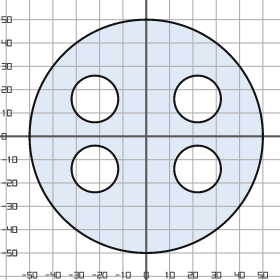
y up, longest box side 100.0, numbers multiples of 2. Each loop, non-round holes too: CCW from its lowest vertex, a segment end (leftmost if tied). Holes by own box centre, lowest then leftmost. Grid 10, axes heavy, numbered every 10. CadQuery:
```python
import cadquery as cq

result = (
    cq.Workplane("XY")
    .moveTo(0.0, 0.0)
    .circle(50.0)
    .moveTo(-22.0, -14.0)
    .circle(10.0)
    .moveTo(22.0, -14.0)
    .circle(10.0)
    .moveTo(-22.0, 16.0)
    .circle(10.0)
    .moveTo(22.0, 16.0)
    .circle(10.0)
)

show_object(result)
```